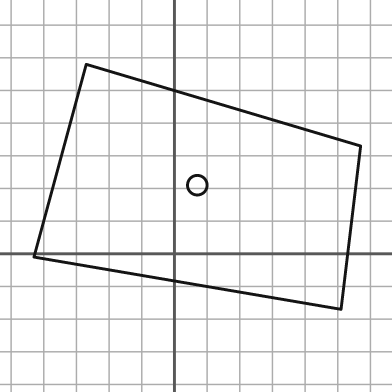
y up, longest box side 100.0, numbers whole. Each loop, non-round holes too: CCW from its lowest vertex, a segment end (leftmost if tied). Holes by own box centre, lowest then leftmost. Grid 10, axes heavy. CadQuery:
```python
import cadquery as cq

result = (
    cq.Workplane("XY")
    .moveTo(51.0, -17.0)
    .lineTo(57.0, 33.0)
    .lineTo(-27.0, 58.0)
    .lineTo(-43.0, -1.0)
    .close()
    .moveTo(7.0, 21.0)
    .circle(3.0)
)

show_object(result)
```